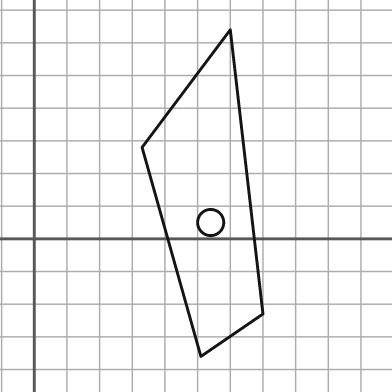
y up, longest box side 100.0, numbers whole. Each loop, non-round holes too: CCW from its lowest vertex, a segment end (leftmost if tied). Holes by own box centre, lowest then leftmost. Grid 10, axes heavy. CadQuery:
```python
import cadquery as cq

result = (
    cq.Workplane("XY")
    .moveTo(51.0, -36.0)
    .lineTo(70.0, -23.0)
    .lineTo(60.0, 64.0)
    .lineTo(33.0, 28.0)
    .close()
    .moveTo(54.0, 5.0)
    .circle(4.0)
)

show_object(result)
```